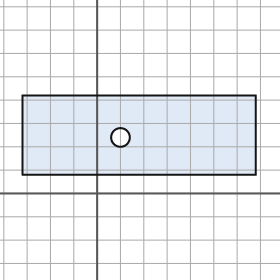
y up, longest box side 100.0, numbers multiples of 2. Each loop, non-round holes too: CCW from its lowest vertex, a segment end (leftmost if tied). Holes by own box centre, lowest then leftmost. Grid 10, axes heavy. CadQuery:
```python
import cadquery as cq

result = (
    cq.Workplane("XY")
    .moveTo(-32.0, 8.0)
    .lineTo(68.0, 8.0)
    .lineTo(68.0, 42.0)
    .lineTo(-32.0, 42.0)
    .close()
    .moveTo(10.0, 24.0)
    .circle(4.0)
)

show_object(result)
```